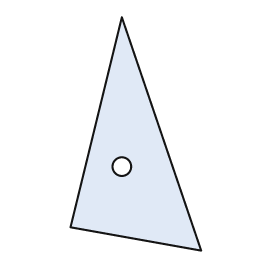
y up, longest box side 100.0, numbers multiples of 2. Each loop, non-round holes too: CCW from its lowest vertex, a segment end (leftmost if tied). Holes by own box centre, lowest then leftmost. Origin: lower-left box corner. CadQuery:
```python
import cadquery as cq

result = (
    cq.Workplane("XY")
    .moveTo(56.0, 0.0)
    .lineTo(22.0, 100.0)
    .lineTo(0.0, 10.0)
    .close()
    .moveTo(22.0, 36.0)
    .circle(4.0)
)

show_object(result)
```